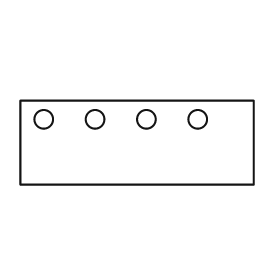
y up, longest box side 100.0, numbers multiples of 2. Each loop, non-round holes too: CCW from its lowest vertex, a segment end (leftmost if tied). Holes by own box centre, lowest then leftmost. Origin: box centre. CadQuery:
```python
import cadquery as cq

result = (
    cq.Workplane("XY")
    .moveTo(-50.0, -18.0)
    .lineTo(50.0, -18.0)
    .lineTo(50.0, 18.0)
    .lineTo(-50.0, 18.0)
    .close()
    .moveTo(-40.0, 10.0)
    .circle(4.0)
    .moveTo(-18.0, 10.0)
    .circle(4.0)
    .moveTo(4.0, 10.0)
    .circle(4.0)
    .moveTo(26.0, 10.0)
    .circle(4.0)
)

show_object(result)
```